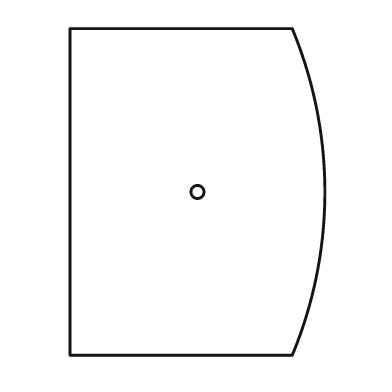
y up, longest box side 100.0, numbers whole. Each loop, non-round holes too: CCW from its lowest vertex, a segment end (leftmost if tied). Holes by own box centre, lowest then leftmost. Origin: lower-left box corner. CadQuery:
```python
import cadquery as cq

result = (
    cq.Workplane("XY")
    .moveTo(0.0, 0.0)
    .lineTo(68.0, 0.0)
    .threePointArc((78.0, 50.0), (68.0, 100.0))
    .lineTo(0.0, 100.0)
    .close()
    .moveTo(39.0, 50.0)
    .circle(2.0)
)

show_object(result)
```